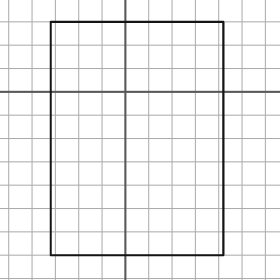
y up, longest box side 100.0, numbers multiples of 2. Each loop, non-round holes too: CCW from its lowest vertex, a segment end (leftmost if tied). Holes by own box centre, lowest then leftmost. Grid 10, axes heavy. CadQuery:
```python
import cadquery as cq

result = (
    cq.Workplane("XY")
    .moveTo(-32.0, -70.0)
    .lineTo(42.0, -70.0)
    .lineTo(42.0, 30.0)
    .lineTo(-32.0, 30.0)
    .close()
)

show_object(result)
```